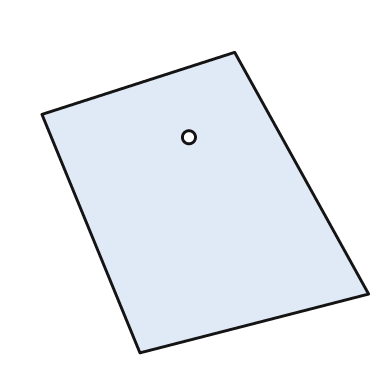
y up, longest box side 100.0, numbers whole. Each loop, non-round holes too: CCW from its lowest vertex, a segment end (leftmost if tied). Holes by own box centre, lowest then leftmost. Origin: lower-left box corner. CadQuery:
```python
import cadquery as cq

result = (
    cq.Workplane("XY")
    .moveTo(30.0, 0.0)
    .lineTo(100.0, 18.0)
    .lineTo(59.0, 92.0)
    .lineTo(0.0, 73.0)
    .close()
    .moveTo(45.0, 66.0)
    .circle(2.0)
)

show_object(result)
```